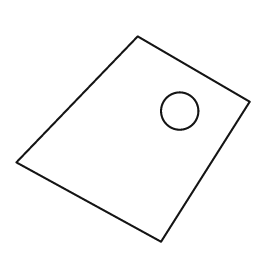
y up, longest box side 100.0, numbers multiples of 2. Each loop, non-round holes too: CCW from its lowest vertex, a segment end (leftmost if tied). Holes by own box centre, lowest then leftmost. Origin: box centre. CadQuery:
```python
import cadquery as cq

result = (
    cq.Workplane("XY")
    .moveTo(12.0, -44.0)
    .lineTo(50.0, 16.0)
    .lineTo(2.0, 44.0)
    .lineTo(-50.0, -10.0)
    .close()
    .moveTo(20.0, 12.0)
    .circle(8.0)
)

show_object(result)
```